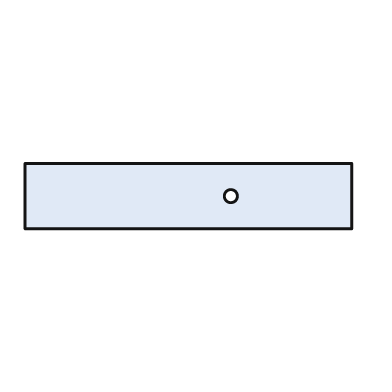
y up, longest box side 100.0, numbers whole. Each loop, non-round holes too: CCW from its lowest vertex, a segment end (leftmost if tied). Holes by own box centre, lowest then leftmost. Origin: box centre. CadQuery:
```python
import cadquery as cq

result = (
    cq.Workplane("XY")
    .moveTo(-50.0, -10.0)
    .lineTo(50.0, -10.0)
    .lineTo(50.0, 10.0)
    .lineTo(-50.0, 10.0)
    .close()
    .moveTo(13.0, 0.0)
    .circle(2.0)
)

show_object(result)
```